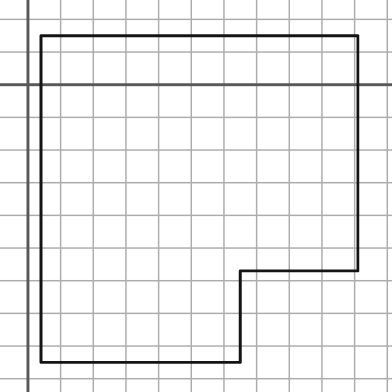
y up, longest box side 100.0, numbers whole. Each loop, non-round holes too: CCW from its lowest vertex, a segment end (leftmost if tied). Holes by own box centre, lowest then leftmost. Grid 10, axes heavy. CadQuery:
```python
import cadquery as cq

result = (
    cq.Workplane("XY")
    .moveTo(4.0, -85.0)
    .lineTo(65.0, -85.0)
    .lineTo(65.0, -57.0)
    .lineTo(101.0, -57.0)
    .lineTo(101.0, 15.0)
    .lineTo(4.0, 15.0)
    .close()
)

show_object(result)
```